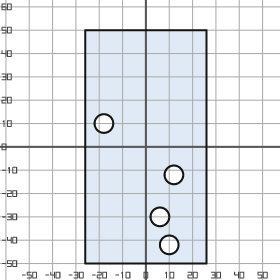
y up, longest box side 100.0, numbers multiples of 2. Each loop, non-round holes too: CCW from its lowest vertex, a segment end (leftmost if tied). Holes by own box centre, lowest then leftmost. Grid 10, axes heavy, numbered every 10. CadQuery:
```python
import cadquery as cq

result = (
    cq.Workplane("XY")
    .moveTo(-26.0, -50.0)
    .lineTo(26.0, -50.0)
    .lineTo(26.0, 50.0)
    .lineTo(-26.0, 50.0)
    .close()
    .moveTo(10.0, -42.0)
    .circle(4.0)
    .moveTo(6.0, -30.0)
    .circle(4.0)
    .moveTo(12.0, -12.0)
    .circle(4.0)
    .moveTo(-18.0, 10.0)
    .circle(4.0)
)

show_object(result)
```